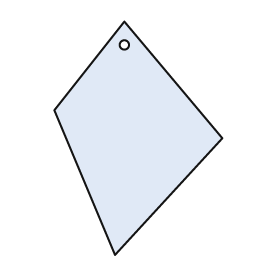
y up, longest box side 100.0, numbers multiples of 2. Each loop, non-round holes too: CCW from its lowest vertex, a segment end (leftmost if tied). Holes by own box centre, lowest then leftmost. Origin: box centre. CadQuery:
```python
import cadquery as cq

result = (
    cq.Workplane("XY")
    .moveTo(-10.0, -50.0)
    .lineTo(36.0, 0.0)
    .lineTo(-6.0, 50.0)
    .lineTo(-36.0, 12.0)
    .close()
    .moveTo(-6.0, 40.0)
    .circle(2.0)
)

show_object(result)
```